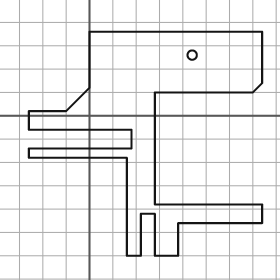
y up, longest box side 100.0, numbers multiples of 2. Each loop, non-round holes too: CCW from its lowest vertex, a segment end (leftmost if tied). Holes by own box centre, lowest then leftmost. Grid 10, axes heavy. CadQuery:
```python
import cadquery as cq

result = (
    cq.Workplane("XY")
    .moveTo(16.0, -60.0)
    .lineTo(22.0, -60.0)
    .lineTo(22.0, -42.0)
    .lineTo(28.0, -42.0)
    .lineTo(28.0, -60.0)
    .lineTo(38.0, -60.0)
    .lineTo(38.0, -46.0)
    .lineTo(74.0, -46.0)
    .lineTo(74.0, -38.0)
    .lineTo(28.0, -38.0)
    .lineTo(28.0, 10.0)
    .lineTo(70.0, 10.0)
    .lineTo(74.0, 14.0)
    .lineTo(74.0, 36.0)
    .lineTo(0.0, 36.0)
    .lineTo(0.0, 12.0)
    .lineTo(-10.0, 2.0)
    .lineTo(-26.0, 2.0)
    .lineTo(-26.0, -6.0)
    .lineTo(18.0, -6.0)
    .lineTo(18.0, -14.0)
    .lineTo(-26.0, -14.0)
    .lineTo(-26.0, -18.0)
    .lineTo(16.0, -18.0)
    .close()
    .moveTo(44.0, 26.0)
    .circle(2.0)
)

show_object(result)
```